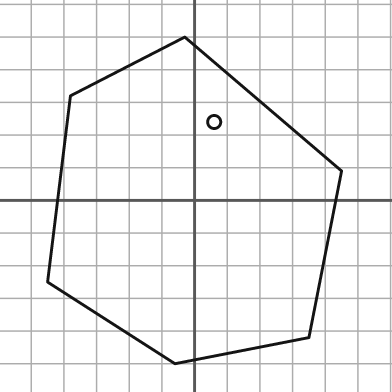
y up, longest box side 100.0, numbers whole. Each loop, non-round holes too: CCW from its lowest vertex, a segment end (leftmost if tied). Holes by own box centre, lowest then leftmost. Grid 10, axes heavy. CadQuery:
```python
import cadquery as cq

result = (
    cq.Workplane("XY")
    .moveTo(-6.0, -50.0)
    .lineTo(35.0, -42.0)
    .lineTo(45.0, 9.0)
    .lineTo(-3.0, 50.0)
    .lineTo(-38.0, 32.0)
    .lineTo(-45.0, -25.0)
    .close()
    .moveTo(6.0, 24.0)
    .circle(2.0)
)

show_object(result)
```